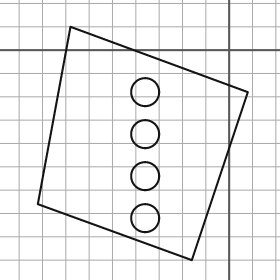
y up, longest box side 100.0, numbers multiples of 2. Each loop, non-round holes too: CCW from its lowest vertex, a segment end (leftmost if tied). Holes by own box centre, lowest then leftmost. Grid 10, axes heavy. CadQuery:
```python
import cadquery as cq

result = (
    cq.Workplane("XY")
    .moveTo(-16.0, -90.0)
    .lineTo(8.0, -18.0)
    .lineTo(-68.0, 10.0)
    .lineTo(-82.0, -66.0)
    .close()
    .moveTo(-36.0, -72.0)
    .circle(6.0)
    .moveTo(-36.0, -54.0)
    .circle(6.0)
    .moveTo(-36.0, -36.0)
    .circle(6.0)
    .moveTo(-36.0, -18.0)
    .circle(6.0)
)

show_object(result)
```